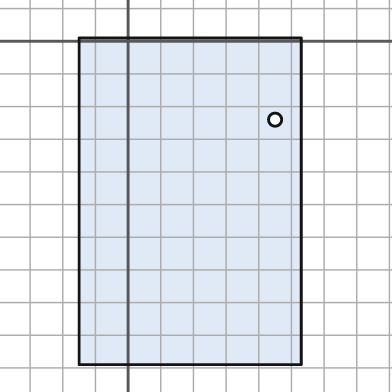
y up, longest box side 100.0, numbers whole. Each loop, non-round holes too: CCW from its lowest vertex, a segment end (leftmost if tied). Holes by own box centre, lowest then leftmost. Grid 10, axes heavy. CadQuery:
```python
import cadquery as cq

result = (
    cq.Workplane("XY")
    .moveTo(-15.0, -99.0)
    .lineTo(53.0, -99.0)
    .lineTo(53.0, 1.0)
    .lineTo(-15.0, 1.0)
    .close()
    .moveTo(45.0, -24.0)
    .circle(2.0)
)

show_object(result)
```